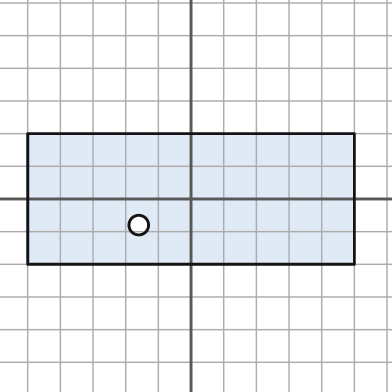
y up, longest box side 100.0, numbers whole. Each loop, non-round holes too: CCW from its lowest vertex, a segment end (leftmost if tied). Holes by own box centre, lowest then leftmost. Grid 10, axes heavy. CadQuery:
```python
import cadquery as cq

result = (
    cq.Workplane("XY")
    .moveTo(-50.0, -20.0)
    .lineTo(50.0, -20.0)
    .lineTo(50.0, 20.0)
    .lineTo(-50.0, 20.0)
    .close()
    .moveTo(-16.0, -8.0)
    .circle(3.0)
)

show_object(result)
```